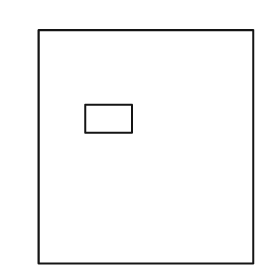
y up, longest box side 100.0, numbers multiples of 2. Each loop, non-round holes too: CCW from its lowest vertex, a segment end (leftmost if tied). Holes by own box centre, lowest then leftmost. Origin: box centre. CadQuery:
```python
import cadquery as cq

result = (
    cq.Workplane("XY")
    .moveTo(-46.0, -50.0)
    .lineTo(46.0, -50.0)
    .lineTo(46.0, 50.0)
    .lineTo(-46.0, 50.0)
    .close()
    .moveTo(-26.0, 6.0)
    .lineTo(-6.0, 6.0)
    .lineTo(-6.0, 18.0)
    .lineTo(-26.0, 18.0)
    .close()
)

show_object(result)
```